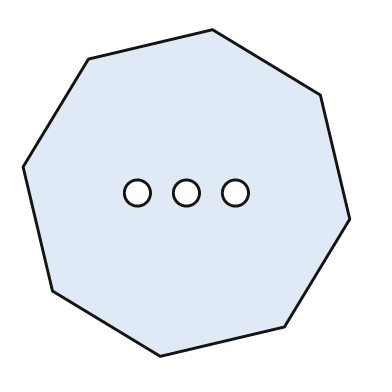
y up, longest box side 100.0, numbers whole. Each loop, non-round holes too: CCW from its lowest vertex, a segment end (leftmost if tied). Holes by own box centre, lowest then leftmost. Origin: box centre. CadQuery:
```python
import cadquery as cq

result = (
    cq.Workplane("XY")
    .moveTo(-8.0, -50.0)
    .lineTo(30.0, -41.0)
    .lineTo(50.0, -8.0)
    .lineTo(41.0, 30.0)
    .lineTo(8.0, 50.0)
    .lineTo(-30.0, 41.0)
    .lineTo(-50.0, 8.0)
    .lineTo(-41.0, -30.0)
    .close()
    .moveTo(-15.0, 0.0)
    .circle(4.0)
    .moveTo(0.0, 0.0)
    .circle(4.0)
    .moveTo(15.0, 0.0)
    .circle(4.0)
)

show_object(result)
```